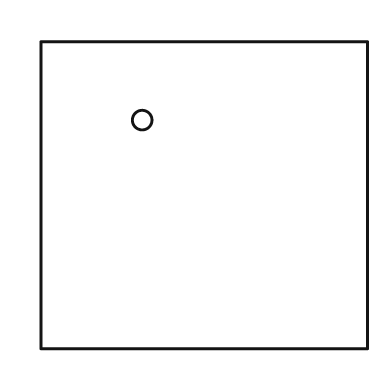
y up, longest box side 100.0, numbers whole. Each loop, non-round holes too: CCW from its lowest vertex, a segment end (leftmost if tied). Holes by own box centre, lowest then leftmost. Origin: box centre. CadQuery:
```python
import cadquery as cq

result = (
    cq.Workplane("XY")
    .moveTo(-50.0, -47.0)
    .lineTo(50.0, -47.0)
    .lineTo(50.0, 47.0)
    .lineTo(-50.0, 47.0)
    .close()
    .moveTo(-19.0, 23.0)
    .circle(3.0)
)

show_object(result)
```